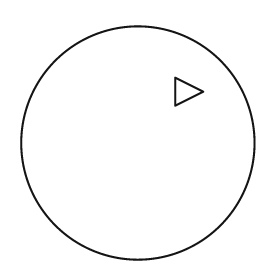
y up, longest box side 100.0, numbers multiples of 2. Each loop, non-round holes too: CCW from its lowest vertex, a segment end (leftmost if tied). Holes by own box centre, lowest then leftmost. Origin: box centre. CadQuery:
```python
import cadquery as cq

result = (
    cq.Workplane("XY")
    .moveTo(0.0, 0.0)
    .circle(50.0)
    .moveTo(16.0, 16.0)
    .lineTo(28.0, 22.0)
    .lineTo(16.0, 28.0)
    .close()
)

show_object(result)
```